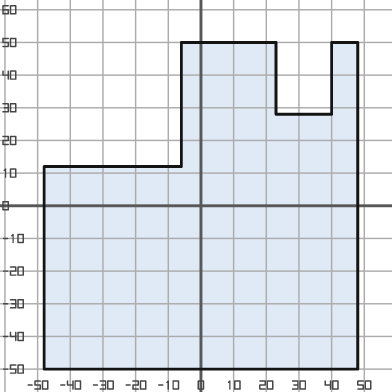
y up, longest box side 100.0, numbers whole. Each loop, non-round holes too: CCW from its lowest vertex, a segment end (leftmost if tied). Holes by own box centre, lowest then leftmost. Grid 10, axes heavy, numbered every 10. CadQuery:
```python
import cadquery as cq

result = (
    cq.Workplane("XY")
    .moveTo(-48.0, -50.0)
    .lineTo(48.0, -50.0)
    .lineTo(48.0, 50.0)
    .lineTo(40.0, 50.0)
    .lineTo(40.0, 28.0)
    .lineTo(23.0, 28.0)
    .lineTo(23.0, 50.0)
    .lineTo(-6.0, 50.0)
    .lineTo(-6.0, 12.0)
    .lineTo(-48.0, 12.0)
    .close()
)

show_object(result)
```